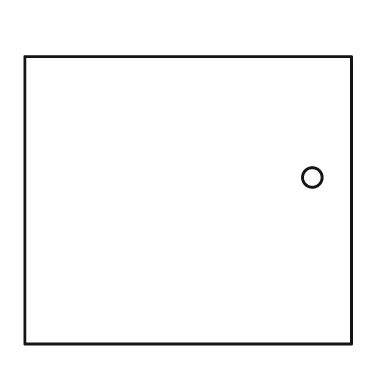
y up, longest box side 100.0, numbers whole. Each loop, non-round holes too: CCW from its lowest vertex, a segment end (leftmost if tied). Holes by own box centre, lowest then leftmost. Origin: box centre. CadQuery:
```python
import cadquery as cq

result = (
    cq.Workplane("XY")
    .moveTo(-50.0, -44.0)
    .lineTo(50.0, -44.0)
    .lineTo(50.0, 44.0)
    .lineTo(-50.0, 44.0)
    .close()
    .moveTo(38.0, 7.0)
    .circle(3.0)
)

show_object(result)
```